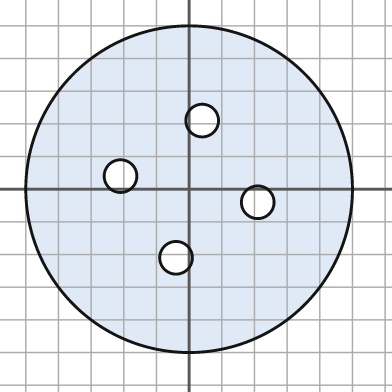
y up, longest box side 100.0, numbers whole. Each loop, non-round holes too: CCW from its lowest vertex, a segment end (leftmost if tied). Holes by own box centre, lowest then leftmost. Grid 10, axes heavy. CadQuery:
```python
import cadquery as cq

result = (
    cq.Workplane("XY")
    .moveTo(0.0, 0.0)
    .circle(50.0)
    .moveTo(-4.0, -21.0)
    .circle(5.0)
    .moveTo(21.0, -4.0)
    .circle(5.0)
    .moveTo(-21.0, 4.0)
    .circle(5.0)
    .moveTo(4.0, 21.0)
    .circle(5.0)
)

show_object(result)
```